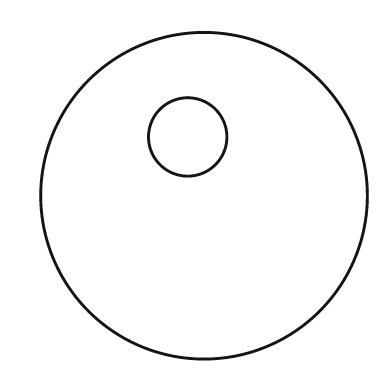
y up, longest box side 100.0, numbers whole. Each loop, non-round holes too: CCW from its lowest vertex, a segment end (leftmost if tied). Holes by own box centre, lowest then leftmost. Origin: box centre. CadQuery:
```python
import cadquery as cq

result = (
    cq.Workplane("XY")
    .moveTo(0.0, 0.0)
    .circle(50.0)
    .moveTo(-5.0, 18.0)
    .circle(12.0)
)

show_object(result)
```